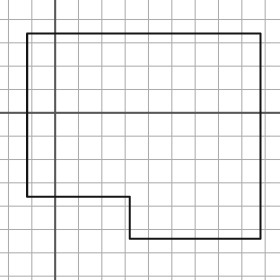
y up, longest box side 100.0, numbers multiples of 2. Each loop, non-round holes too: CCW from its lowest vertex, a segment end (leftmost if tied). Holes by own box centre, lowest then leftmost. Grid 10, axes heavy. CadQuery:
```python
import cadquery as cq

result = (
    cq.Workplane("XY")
    .moveTo(32.0, -54.0)
    .lineTo(88.0, -54.0)
    .lineTo(88.0, 34.0)
    .lineTo(-12.0, 34.0)
    .lineTo(-12.0, -36.0)
    .lineTo(32.0, -36.0)
    .close()
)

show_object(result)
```